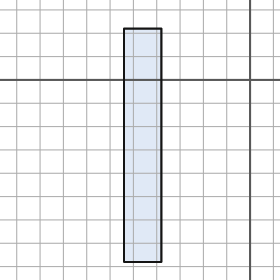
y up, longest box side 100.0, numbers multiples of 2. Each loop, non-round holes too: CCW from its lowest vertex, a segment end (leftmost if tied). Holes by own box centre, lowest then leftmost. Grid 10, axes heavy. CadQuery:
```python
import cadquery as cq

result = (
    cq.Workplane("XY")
    .moveTo(-54.0, -78.0)
    .lineTo(-38.0, -78.0)
    .lineTo(-38.0, 22.0)
    .lineTo(-54.0, 22.0)
    .close()
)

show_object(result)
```